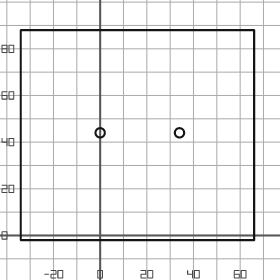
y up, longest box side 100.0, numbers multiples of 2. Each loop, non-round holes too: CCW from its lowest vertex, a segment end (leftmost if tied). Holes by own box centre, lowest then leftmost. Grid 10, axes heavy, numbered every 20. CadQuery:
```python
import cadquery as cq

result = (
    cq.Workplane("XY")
    .moveTo(-34.0, -2.0)
    .lineTo(66.0, -2.0)
    .lineTo(66.0, 88.0)
    .lineTo(-34.0, 88.0)
    .close()
    .moveTo(0.0, 44.0)
    .circle(2.0)
    .moveTo(34.0, 44.0)
    .circle(2.0)
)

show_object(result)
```